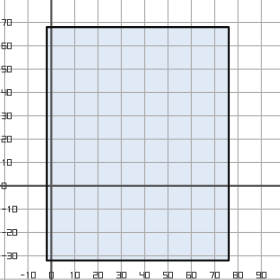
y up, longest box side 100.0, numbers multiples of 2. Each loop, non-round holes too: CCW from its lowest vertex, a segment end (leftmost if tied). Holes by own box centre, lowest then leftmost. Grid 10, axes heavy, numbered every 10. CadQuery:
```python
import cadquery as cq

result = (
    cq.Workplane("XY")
    .moveTo(-2.0, -32.0)
    .lineTo(76.0, -32.0)
    .lineTo(76.0, 68.0)
    .lineTo(-2.0, 68.0)
    .close()
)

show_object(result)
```